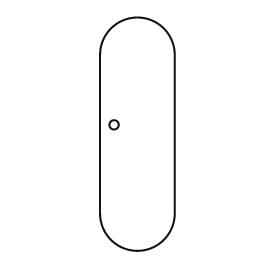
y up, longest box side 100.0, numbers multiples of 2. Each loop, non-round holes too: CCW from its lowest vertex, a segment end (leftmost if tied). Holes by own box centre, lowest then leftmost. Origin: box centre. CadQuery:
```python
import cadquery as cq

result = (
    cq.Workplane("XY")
    .moveTo(-16.0, -34.0)
    .threePointArc((0.0, -50.0), (16.0, -34.0))
    .lineTo(16.0, 34.0)
    .threePointArc((0.0, 50.0), (-16.0, 34.0))
    .close()
    .moveTo(-10.0, 4.0)
    .circle(2.0)
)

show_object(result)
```